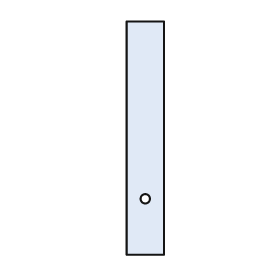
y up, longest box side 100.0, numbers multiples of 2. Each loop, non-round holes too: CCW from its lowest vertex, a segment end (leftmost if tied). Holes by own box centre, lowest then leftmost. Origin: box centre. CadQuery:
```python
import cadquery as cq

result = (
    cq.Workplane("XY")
    .moveTo(-8.0, -50.0)
    .lineTo(8.0, -50.0)
    .lineTo(8.0, 50.0)
    .lineTo(-8.0, 50.0)
    .close()
    .moveTo(0.0, -26.0)
    .circle(2.0)
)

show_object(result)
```